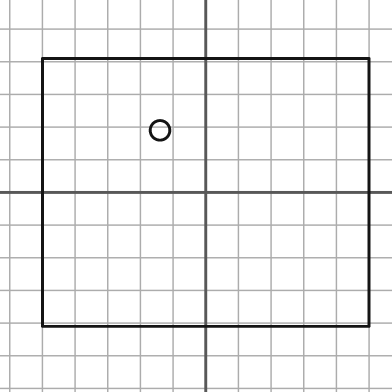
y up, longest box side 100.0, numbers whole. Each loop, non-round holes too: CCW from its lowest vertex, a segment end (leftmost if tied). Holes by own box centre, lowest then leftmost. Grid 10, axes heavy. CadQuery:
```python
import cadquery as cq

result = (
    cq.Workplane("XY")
    .moveTo(-50.0, -41.0)
    .lineTo(50.0, -41.0)
    .lineTo(50.0, 41.0)
    .lineTo(-50.0, 41.0)
    .close()
    .moveTo(-14.0, 19.0)
    .circle(3.0)
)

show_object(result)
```